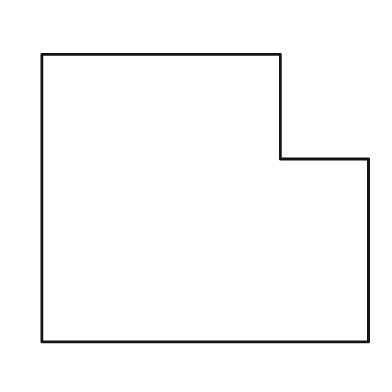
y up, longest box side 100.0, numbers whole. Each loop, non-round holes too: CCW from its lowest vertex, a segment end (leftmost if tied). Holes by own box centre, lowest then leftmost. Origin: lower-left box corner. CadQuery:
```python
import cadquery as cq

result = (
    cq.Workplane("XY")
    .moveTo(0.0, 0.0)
    .lineTo(100.0, 0.0)
    .lineTo(100.0, 56.0)
    .lineTo(73.0, 56.0)
    .lineTo(73.0, 88.0)
    .lineTo(0.0, 88.0)
    .close()
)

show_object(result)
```